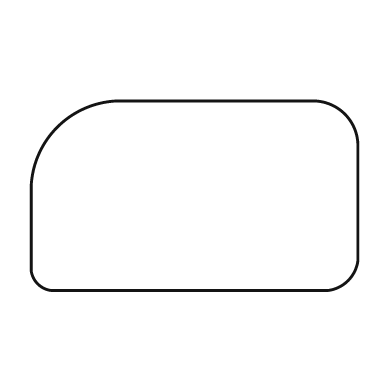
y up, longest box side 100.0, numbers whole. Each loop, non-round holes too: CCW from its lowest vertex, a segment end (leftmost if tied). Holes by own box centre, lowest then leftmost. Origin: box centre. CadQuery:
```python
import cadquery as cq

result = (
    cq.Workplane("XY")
    .moveTo(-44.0, -29.0)
    .lineTo(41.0, -29.0)
    .threePointArc((47.0, -26.0), (50.0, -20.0))
    .lineTo(50.0, 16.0)
    .threePointArc((46.0, 25.0), (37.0, 29.0))
    .lineTo(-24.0, 29.0)
    .threePointArc((-42.0, 21.0), (-50.0, 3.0))
    .lineTo(-50.0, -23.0)
    .threePointArc((-48.0, -27.0), (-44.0, -29.0))
    .close()
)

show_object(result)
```